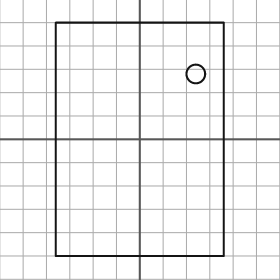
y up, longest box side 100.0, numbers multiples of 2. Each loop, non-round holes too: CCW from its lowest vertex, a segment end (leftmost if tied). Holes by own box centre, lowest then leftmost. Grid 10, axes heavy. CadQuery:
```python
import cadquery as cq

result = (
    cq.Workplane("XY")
    .moveTo(-36.0, -50.0)
    .lineTo(36.0, -50.0)
    .lineTo(36.0, 50.0)
    .lineTo(-36.0, 50.0)
    .close()
    .moveTo(24.0, 28.0)
    .circle(4.0)
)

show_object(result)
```